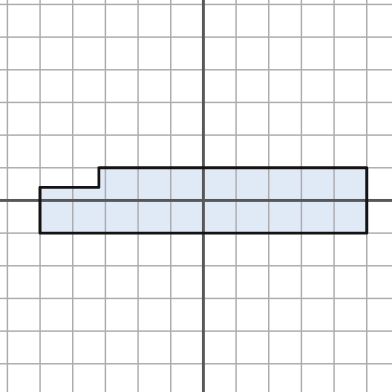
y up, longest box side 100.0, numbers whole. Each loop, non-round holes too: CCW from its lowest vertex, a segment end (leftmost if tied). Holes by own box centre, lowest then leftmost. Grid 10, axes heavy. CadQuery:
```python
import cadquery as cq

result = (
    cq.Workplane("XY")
    .moveTo(-50.0, -10.0)
    .lineTo(50.0, -10.0)
    .lineTo(50.0, 10.0)
    .lineTo(-32.0, 10.0)
    .lineTo(-32.0, 4.0)
    .lineTo(-50.0, 4.0)
    .close()
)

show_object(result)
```